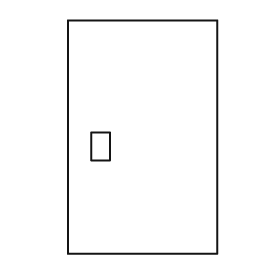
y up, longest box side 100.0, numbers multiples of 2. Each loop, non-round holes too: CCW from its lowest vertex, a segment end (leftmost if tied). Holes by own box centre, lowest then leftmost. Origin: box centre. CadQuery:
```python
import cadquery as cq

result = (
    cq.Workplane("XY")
    .moveTo(-32.0, -50.0)
    .lineTo(32.0, -50.0)
    .lineTo(32.0, 50.0)
    .lineTo(-32.0, 50.0)
    .close()
    .moveTo(-22.0, -10.0)
    .lineTo(-14.0, -10.0)
    .lineTo(-14.0, 2.0)
    .lineTo(-22.0, 2.0)
    .close()
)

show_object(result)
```